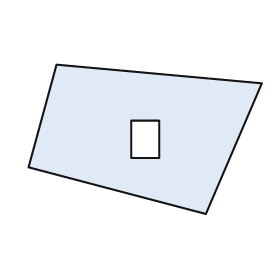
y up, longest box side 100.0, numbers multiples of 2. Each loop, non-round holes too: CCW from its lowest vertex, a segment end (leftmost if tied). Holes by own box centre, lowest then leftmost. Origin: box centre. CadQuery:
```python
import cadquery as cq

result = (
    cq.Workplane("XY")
    .moveTo(26.0, -32.0)
    .lineTo(50.0, 24.0)
    .lineTo(-38.0, 32.0)
    .lineTo(-50.0, -12.0)
    .close()
    .moveTo(-6.0, -8.0)
    .lineTo(6.0, -8.0)
    .lineTo(6.0, 8.0)
    .lineTo(-6.0, 8.0)
    .close()
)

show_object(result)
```